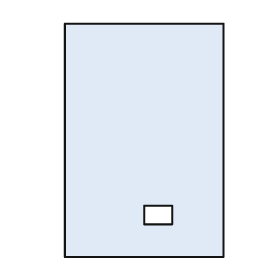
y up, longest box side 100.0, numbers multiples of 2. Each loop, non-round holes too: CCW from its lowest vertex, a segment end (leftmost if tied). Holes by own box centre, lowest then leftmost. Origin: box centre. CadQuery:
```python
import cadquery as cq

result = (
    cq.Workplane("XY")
    .moveTo(-34.0, -50.0)
    .lineTo(34.0, -50.0)
    .lineTo(34.0, 50.0)
    .lineTo(-34.0, 50.0)
    .close()
    .moveTo(0.0, -36.0)
    .lineTo(12.0, -36.0)
    .lineTo(12.0, -28.0)
    .lineTo(0.0, -28.0)
    .close()
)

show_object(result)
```